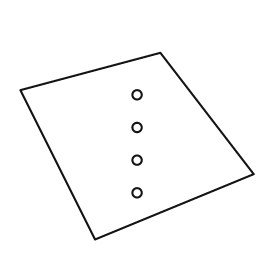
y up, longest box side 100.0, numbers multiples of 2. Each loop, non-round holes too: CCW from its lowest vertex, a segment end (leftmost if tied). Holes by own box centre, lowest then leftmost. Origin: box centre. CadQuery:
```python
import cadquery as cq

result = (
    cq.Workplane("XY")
    .moveTo(-18.0, -40.0)
    .lineTo(50.0, -12.0)
    .lineTo(10.0, 40.0)
    .lineTo(-50.0, 24.0)
    .close()
    .moveTo(0.0, -20.0)
    .circle(2.0)
    .moveTo(0.0, -6.0)
    .circle(2.0)
    .moveTo(0.0, 8.0)
    .circle(2.0)
    .moveTo(0.0, 22.0)
    .circle(2.0)
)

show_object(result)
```